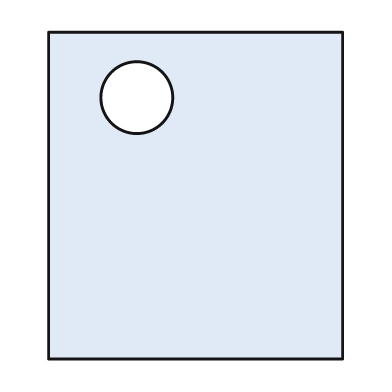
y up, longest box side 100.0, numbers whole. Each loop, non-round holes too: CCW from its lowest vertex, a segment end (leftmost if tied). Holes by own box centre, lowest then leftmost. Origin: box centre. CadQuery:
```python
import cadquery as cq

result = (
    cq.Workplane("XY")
    .moveTo(-45.0, -50.0)
    .lineTo(45.0, -50.0)
    .lineTo(45.0, 50.0)
    .lineTo(-45.0, 50.0)
    .close()
    .moveTo(-18.0, 30.0)
    .circle(11.0)
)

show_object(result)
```